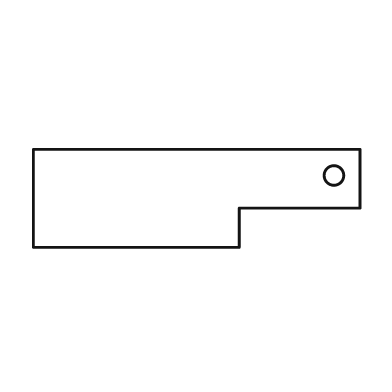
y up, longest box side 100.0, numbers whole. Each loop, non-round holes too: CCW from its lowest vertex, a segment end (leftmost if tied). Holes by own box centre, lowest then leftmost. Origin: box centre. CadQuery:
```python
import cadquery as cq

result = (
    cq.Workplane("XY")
    .moveTo(-50.0, -15.0)
    .lineTo(13.0, -15.0)
    .lineTo(13.0, -3.0)
    .lineTo(50.0, -3.0)
    .lineTo(50.0, 15.0)
    .lineTo(-50.0, 15.0)
    .close()
    .moveTo(42.0, 7.0)
    .circle(3.0)
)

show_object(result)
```